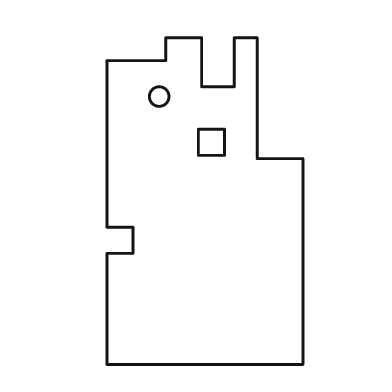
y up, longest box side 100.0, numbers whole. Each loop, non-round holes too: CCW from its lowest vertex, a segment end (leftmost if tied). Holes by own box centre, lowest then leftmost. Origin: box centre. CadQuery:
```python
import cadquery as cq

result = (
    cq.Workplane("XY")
    .moveTo(-30.0, -50.0)
    .lineTo(30.0, -50.0)
    .lineTo(30.0, 13.0)
    .lineTo(16.0, 13.0)
    .lineTo(16.0, 50.0)
    .lineTo(9.0, 50.0)
    .lineTo(9.0, 35.0)
    .lineTo(-1.0, 35.0)
    .lineTo(-1.0, 50.0)
    .lineTo(-12.0, 50.0)
    .lineTo(-12.0, 43.0)
    .lineTo(-30.0, 43.0)
    .lineTo(-30.0, -8.0)
    .lineTo(-22.0, -8.0)
    .lineTo(-22.0, -16.0)
    .lineTo(-30.0, -16.0)
    .close()
    .moveTo(-2.0, 14.0)
    .lineTo(6.0, 14.0)
    .lineTo(6.0, 22.0)
    .lineTo(-2.0, 22.0)
    .close()
    .moveTo(-14.0, 32.0)
    .circle(3.0)
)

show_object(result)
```